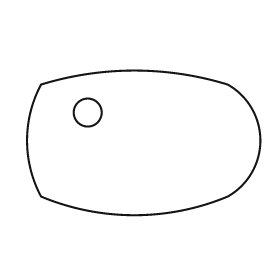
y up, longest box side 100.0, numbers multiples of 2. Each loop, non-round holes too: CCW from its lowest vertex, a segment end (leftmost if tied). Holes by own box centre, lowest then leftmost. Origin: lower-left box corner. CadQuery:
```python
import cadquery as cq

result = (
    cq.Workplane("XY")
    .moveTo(6.0, 8.0)
    .threePointArc((46.0, 0.0), (86.0, 8.0))
    .threePointArc((100.0, 32.0), (86.0, 56.0))
    .threePointArc((46.0, 62.0), (6.0, 56.0))
    .threePointArc((0.0, 32.0), (6.0, 8.0))
    .close()
    .moveTo(26.0, 44.0)
    .circle(6.0)
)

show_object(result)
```